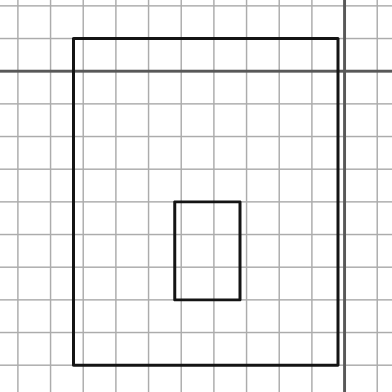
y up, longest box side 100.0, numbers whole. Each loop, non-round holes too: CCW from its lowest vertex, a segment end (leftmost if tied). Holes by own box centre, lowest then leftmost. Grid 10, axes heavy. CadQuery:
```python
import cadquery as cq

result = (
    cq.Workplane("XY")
    .moveTo(-83.0, -90.0)
    .lineTo(-2.0, -90.0)
    .lineTo(-2.0, 10.0)
    .lineTo(-83.0, 10.0)
    .close()
    .moveTo(-52.0, -70.0)
    .lineTo(-32.0, -70.0)
    .lineTo(-32.0, -40.0)
    .lineTo(-52.0, -40.0)
    .close()
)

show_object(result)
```